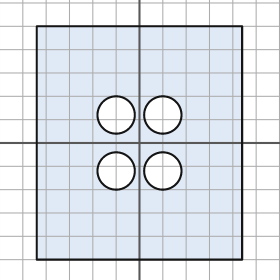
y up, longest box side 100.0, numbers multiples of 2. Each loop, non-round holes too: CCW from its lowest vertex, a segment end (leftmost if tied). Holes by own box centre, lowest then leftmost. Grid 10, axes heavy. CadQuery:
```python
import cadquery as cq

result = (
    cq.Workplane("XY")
    .moveTo(-44.0, -50.0)
    .lineTo(44.0, -50.0)
    .lineTo(44.0, 50.0)
    .lineTo(-44.0, 50.0)
    .close()
    .moveTo(-10.0, -12.0)
    .circle(8.0)
    .moveTo(10.0, -12.0)
    .circle(8.0)
    .moveTo(-10.0, 12.0)
    .circle(8.0)
    .moveTo(10.0, 12.0)
    .circle(8.0)
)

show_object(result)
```